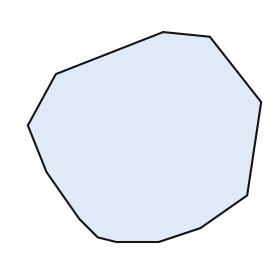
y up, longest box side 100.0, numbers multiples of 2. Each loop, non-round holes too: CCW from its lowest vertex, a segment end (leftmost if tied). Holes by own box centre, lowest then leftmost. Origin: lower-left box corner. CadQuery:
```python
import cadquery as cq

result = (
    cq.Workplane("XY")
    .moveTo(38.0, 0.0)
    .lineTo(56.0, 0.0)
    .lineTo(74.0, 6.0)
    .lineTo(94.0, 20.0)
    .lineTo(100.0, 60.0)
    .lineTo(78.0, 88.0)
    .lineTo(58.0, 90.0)
    .lineTo(12.0, 72.0)
    .lineTo(0.0, 50.0)
    .lineTo(8.0, 30.0)
    .lineTo(22.0, 10.0)
    .lineTo(30.0, 2.0)
    .close()
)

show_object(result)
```